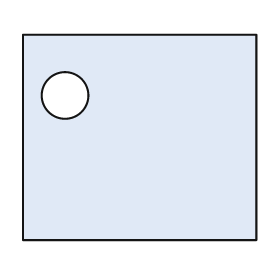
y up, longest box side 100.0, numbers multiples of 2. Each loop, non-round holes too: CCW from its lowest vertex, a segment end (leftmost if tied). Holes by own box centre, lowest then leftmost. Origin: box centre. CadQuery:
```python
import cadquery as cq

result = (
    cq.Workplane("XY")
    .moveTo(-50.0, -44.0)
    .lineTo(50.0, -44.0)
    .lineTo(50.0, 44.0)
    .lineTo(-50.0, 44.0)
    .close()
    .moveTo(-32.0, 18.0)
    .circle(10.0)
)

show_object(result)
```